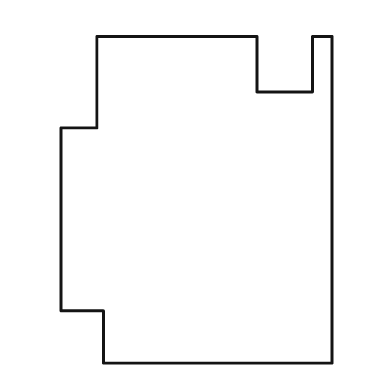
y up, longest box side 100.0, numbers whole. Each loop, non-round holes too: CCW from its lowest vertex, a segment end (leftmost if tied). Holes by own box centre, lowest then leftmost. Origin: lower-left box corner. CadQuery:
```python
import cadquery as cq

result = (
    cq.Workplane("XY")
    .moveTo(13.0, 0.0)
    .lineTo(83.0, 0.0)
    .lineTo(83.0, 100.0)
    .lineTo(77.0, 100.0)
    .lineTo(77.0, 83.0)
    .lineTo(60.0, 83.0)
    .lineTo(60.0, 100.0)
    .lineTo(11.0, 100.0)
    .lineTo(11.0, 72.0)
    .lineTo(0.0, 72.0)
    .lineTo(0.0, 16.0)
    .lineTo(13.0, 16.0)
    .close()
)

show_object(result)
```